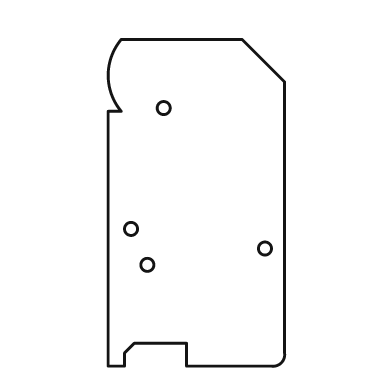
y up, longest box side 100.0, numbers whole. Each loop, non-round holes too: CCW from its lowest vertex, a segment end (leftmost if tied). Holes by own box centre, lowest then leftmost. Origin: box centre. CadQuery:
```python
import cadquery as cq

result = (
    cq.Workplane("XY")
    .moveTo(-27.0, -50.0)
    .lineTo(-22.0, -50.0)
    .lineTo(-22.0, -46.0)
    .lineTo(-19.0, -43.0)
    .lineTo(-3.0, -43.0)
    .lineTo(-3.0, -50.0)
    .lineTo(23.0, -50.0)
    .threePointArc((26.0, -49.0), (27.0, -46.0))
    .lineTo(27.0, 37.0)
    .lineTo(14.0, 50.0)
    .lineTo(-23.0, 50.0)
    .threePointArc((-27.0, 39.0), (-23.0, 28.0))
    .lineTo(-27.0, 28.0)
    .close()
    .moveTo(-15.0, -19.0)
    .circle(2.0)
    .moveTo(21.0, -14.0)
    .circle(2.0)
    .moveTo(-20.0, -8.0)
    .circle(2.0)
    .moveTo(-10.0, 29.0)
    .circle(2.0)
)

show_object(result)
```